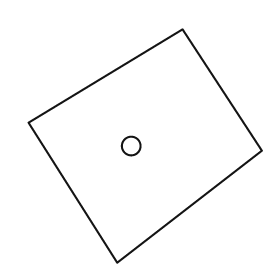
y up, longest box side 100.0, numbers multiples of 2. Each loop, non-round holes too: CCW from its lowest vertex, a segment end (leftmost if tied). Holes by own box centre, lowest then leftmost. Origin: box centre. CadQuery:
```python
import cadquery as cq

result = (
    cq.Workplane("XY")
    .moveTo(-12.0, -50.0)
    .lineTo(50.0, -2.0)
    .lineTo(16.0, 50.0)
    .lineTo(-50.0, 10.0)
    .close()
    .moveTo(-6.0, 0.0)
    .circle(4.0)
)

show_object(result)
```